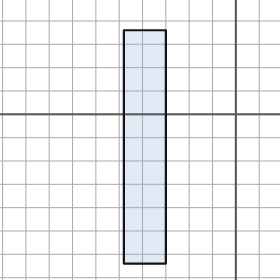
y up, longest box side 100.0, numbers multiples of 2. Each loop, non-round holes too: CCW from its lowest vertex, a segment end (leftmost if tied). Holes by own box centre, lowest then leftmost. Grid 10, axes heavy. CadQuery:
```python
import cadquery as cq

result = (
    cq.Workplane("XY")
    .moveTo(-48.0, -64.0)
    .lineTo(-30.0, -64.0)
    .lineTo(-30.0, 36.0)
    .lineTo(-48.0, 36.0)
    .close()
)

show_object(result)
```